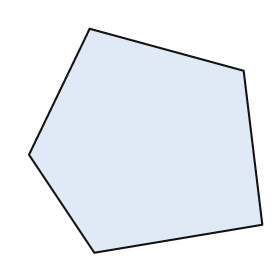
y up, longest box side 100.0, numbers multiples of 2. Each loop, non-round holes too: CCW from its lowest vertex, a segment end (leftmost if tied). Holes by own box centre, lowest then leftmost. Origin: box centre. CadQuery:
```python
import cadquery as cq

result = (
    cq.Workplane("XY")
    .moveTo(-22.0, -48.0)
    .lineTo(50.0, -36.0)
    .lineTo(42.0, 30.0)
    .lineTo(-24.0, 48.0)
    .lineTo(-50.0, -6.0)
    .close()
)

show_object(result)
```